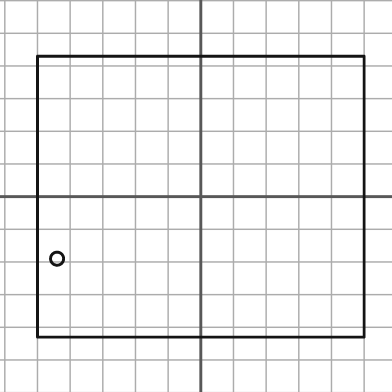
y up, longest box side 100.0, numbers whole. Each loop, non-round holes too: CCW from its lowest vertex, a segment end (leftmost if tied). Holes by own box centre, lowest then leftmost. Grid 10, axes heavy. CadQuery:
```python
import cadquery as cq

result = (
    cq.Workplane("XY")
    .moveTo(-50.0, -43.0)
    .lineTo(50.0, -43.0)
    .lineTo(50.0, 43.0)
    .lineTo(-50.0, 43.0)
    .close()
    .moveTo(-44.0, -19.0)
    .circle(2.0)
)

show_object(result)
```